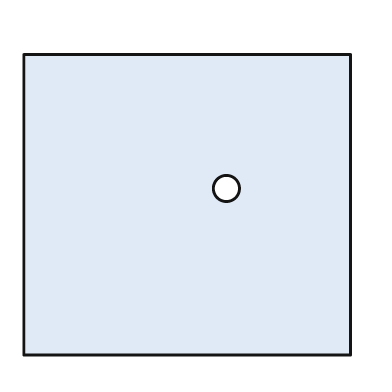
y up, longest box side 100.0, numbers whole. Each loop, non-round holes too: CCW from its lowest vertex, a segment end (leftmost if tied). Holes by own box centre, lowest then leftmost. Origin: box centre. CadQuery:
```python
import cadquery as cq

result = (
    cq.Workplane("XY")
    .moveTo(-50.0, -46.0)
    .lineTo(50.0, -46.0)
    .lineTo(50.0, 46.0)
    .lineTo(-50.0, 46.0)
    .close()
    .moveTo(12.0, 5.0)
    .circle(4.0)
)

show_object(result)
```